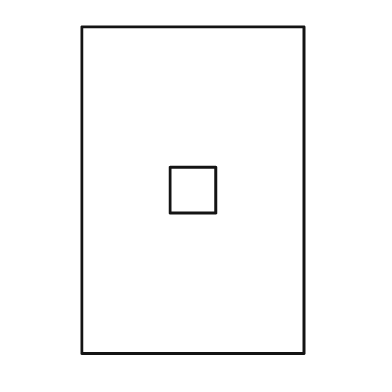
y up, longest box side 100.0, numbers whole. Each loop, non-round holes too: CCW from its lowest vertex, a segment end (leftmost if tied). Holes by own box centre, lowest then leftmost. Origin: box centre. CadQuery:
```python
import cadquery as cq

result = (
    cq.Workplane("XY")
    .moveTo(-34.0, -50.0)
    .lineTo(34.0, -50.0)
    .lineTo(34.0, 50.0)
    .lineTo(-34.0, 50.0)
    .close()
    .moveTo(-7.0, -7.0)
    .lineTo(7.0, -7.0)
    .lineTo(7.0, 7.0)
    .lineTo(-7.0, 7.0)
    .close()
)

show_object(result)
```